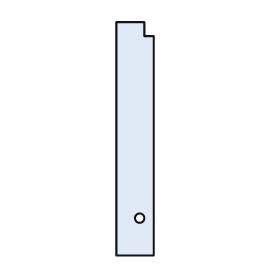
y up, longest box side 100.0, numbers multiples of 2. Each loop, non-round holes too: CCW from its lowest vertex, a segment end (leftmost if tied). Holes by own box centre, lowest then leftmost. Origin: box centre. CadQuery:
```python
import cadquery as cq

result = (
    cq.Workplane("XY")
    .moveTo(-8.0, -50.0)
    .lineTo(8.0, -50.0)
    .lineTo(8.0, 44.0)
    .lineTo(4.0, 44.0)
    .lineTo(4.0, 50.0)
    .lineTo(-8.0, 50.0)
    .close()
    .moveTo(2.0, -34.0)
    .circle(2.0)
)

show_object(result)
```